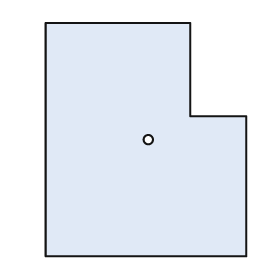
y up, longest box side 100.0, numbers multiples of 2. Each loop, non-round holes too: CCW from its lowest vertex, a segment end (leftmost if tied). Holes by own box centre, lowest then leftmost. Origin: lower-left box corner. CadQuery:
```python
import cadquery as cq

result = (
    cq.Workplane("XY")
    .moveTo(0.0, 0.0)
    .lineTo(86.0, 0.0)
    .lineTo(86.0, 60.0)
    .lineTo(62.0, 60.0)
    .lineTo(62.0, 100.0)
    .lineTo(0.0, 100.0)
    .close()
    .moveTo(44.0, 50.0)
    .circle(2.0)
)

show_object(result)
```